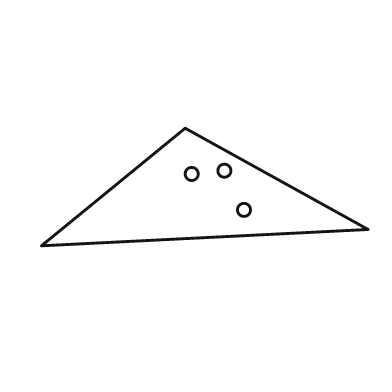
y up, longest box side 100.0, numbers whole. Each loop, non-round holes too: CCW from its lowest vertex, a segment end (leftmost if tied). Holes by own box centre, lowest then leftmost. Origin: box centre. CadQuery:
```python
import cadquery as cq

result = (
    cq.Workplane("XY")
    .moveTo(-50.0, -18.0)
    .lineTo(50.0, -13.0)
    .lineTo(-6.0, 18.0)
    .close()
    .moveTo(12.0, -7.0)
    .circle(2.0)
    .moveTo(-4.0, 4.0)
    .circle(2.0)
    .moveTo(6.0, 5.0)
    .circle(2.0)
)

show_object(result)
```